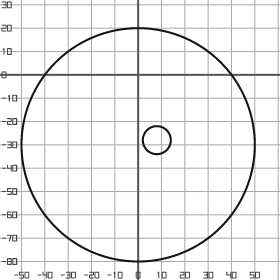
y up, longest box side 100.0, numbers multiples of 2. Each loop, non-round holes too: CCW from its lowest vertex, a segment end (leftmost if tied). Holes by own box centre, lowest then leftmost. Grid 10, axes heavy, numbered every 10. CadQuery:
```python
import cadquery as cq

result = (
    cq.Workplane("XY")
    .moveTo(0.0, -30.0)
    .circle(50.0)
    .moveTo(8.0, -28.0)
    .circle(6.0)
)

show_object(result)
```